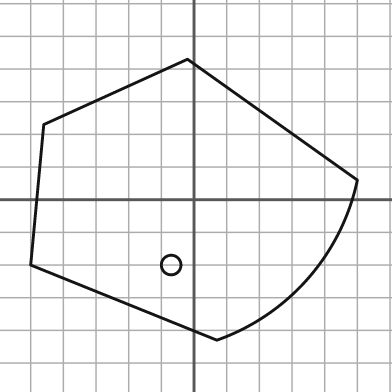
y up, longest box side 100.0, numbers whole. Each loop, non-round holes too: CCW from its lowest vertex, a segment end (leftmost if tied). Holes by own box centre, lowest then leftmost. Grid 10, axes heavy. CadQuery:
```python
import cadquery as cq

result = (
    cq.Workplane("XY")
    .moveTo(7.0, -43.0)
    .threePointArc((35.0, -24.0), (50.0, 6.0))
    .lineTo(-2.0, 43.0)
    .lineTo(-46.0, 23.0)
    .lineTo(-50.0, -20.0)
    .close()
    .moveTo(-7.0, -20.0)
    .circle(3.0)
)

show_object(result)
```